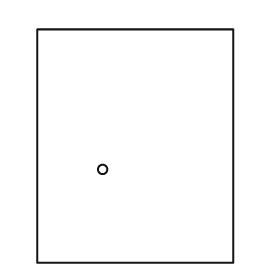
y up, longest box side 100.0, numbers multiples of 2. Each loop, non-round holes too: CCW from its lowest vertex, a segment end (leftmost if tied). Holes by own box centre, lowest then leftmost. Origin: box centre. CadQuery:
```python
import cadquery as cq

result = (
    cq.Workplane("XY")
    .moveTo(-42.0, -50.0)
    .lineTo(42.0, -50.0)
    .lineTo(42.0, 50.0)
    .lineTo(-42.0, 50.0)
    .close()
    .moveTo(-14.0, -10.0)
    .circle(2.0)
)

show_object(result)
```